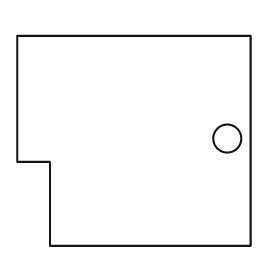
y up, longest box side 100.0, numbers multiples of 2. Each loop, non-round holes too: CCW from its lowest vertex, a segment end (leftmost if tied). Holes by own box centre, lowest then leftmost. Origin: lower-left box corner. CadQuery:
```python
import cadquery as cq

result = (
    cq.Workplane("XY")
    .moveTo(14.0, 0.0)
    .lineTo(100.0, 0.0)
    .lineTo(100.0, 90.0)
    .lineTo(0.0, 90.0)
    .lineTo(0.0, 36.0)
    .lineTo(14.0, 36.0)
    .close()
    .moveTo(90.0, 46.0)
    .circle(6.0)
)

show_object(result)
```